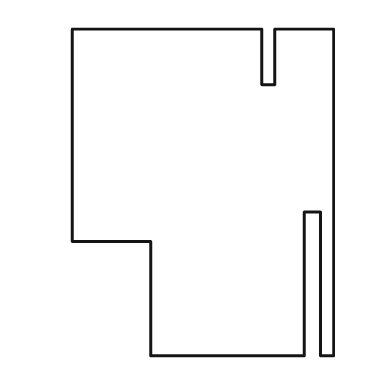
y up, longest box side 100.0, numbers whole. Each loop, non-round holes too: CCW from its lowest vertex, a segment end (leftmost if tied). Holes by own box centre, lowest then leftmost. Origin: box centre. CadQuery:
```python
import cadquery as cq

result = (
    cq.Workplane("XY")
    .moveTo(-16.0, -50.0)
    .lineTo(31.0, -50.0)
    .lineTo(31.0, -6.0)
    .lineTo(36.0, -6.0)
    .lineTo(36.0, -50.0)
    .lineTo(40.0, -50.0)
    .lineTo(40.0, 50.0)
    .lineTo(22.0, 50.0)
    .lineTo(22.0, 33.0)
    .lineTo(18.0, 33.0)
    .lineTo(18.0, 50.0)
    .lineTo(-40.0, 50.0)
    .lineTo(-40.0, -15.0)
    .lineTo(-16.0, -15.0)
    .close()
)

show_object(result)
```